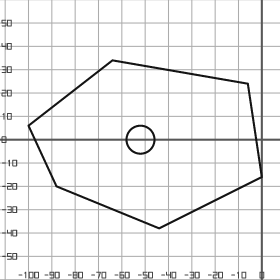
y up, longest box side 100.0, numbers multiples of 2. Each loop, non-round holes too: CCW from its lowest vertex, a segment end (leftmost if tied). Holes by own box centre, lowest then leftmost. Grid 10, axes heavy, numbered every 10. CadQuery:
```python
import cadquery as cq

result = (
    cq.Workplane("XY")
    .moveTo(-44.0, -38.0)
    .lineTo(0.0, -16.0)
    .lineTo(-6.0, 24.0)
    .lineTo(-64.0, 34.0)
    .lineTo(-100.0, 6.0)
    .lineTo(-88.0, -20.0)
    .close()
    .moveTo(-52.0, 0.0)
    .circle(6.0)
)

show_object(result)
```